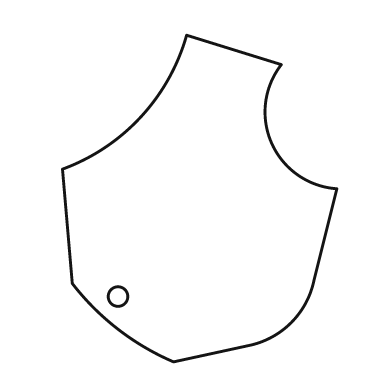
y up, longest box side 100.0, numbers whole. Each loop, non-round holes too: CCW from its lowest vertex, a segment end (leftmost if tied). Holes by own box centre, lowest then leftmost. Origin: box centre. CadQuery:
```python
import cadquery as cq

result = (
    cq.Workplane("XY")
    .moveTo(-8.0, -50.0)
    .lineTo(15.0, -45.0)
    .threePointArc((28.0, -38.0), (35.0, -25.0))
    .lineTo(42.0, 3.0)
    .threePointArc((22.0, 17.0), (25.0, 41.0))
    .lineTo(-4.0, 50.0)
    .threePointArc((-18.0, 25.0), (-42.0, 9.0))
    .lineTo(-39.0, -26.0)
    .threePointArc((-25.0, -40.0), (-8.0, -50.0))
    .close()
    .moveTo(-25.0, -30.0)
    .circle(3.0)
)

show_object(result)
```